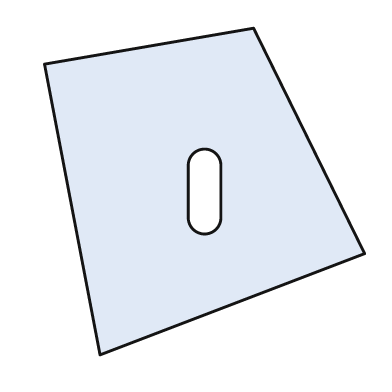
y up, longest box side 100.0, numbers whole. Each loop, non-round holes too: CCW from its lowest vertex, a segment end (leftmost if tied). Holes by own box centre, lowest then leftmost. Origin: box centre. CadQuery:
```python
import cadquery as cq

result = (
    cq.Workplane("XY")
    .moveTo(-32.0, -50.0)
    .lineTo(49.0, -19.0)
    .lineTo(15.0, 50.0)
    .lineTo(-49.0, 39.0)
    .close()
    .moveTo(-5.0, -8.0)
    .threePointArc((0.0, -13.0), (5.0, -8.0))
    .lineTo(5.0, 8.0)
    .threePointArc((0.0, 13.0), (-5.0, 8.0))
    .close()
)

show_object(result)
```